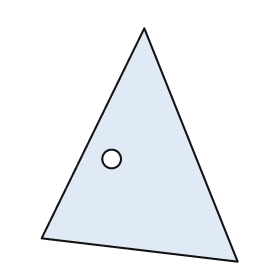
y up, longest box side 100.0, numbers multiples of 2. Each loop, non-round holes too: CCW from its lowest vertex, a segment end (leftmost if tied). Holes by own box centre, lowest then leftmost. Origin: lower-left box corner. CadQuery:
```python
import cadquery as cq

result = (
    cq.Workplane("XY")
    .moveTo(84.0, 0.0)
    .lineTo(44.0, 100.0)
    .lineTo(0.0, 10.0)
    .close()
    .moveTo(30.0, 44.0)
    .circle(4.0)
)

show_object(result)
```